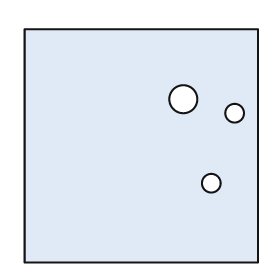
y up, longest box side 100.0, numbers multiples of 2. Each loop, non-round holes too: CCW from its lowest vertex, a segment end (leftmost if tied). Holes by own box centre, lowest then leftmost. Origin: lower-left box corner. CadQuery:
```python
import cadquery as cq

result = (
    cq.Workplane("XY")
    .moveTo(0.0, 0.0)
    .lineTo(100.0, 0.0)
    .lineTo(100.0, 100.0)
    .lineTo(0.0, 100.0)
    .close()
    .moveTo(80.0, 34.0)
    .circle(4.0)
    .moveTo(90.0, 64.0)
    .circle(4.0)
    .moveTo(68.0, 70.0)
    .circle(6.0)
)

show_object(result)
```